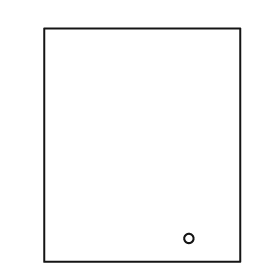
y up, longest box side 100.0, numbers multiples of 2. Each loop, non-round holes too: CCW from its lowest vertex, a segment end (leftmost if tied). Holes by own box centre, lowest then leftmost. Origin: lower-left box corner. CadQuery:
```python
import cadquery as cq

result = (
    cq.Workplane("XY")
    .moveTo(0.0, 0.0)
    .lineTo(84.0, 0.0)
    .lineTo(84.0, 100.0)
    .lineTo(0.0, 100.0)
    .close()
    .moveTo(62.0, 10.0)
    .circle(2.0)
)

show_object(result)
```